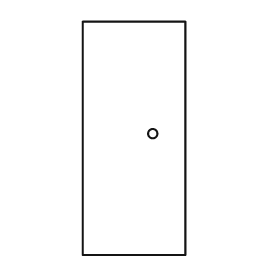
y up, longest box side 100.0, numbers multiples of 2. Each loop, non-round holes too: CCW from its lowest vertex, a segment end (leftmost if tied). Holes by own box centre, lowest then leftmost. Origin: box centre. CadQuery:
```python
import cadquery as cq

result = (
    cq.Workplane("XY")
    .moveTo(-22.0, -50.0)
    .lineTo(22.0, -50.0)
    .lineTo(22.0, 50.0)
    .lineTo(-22.0, 50.0)
    .close()
    .moveTo(8.0, 2.0)
    .circle(2.0)
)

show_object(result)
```